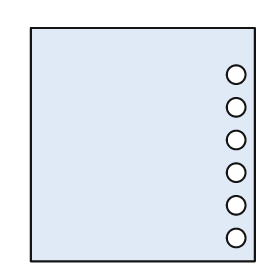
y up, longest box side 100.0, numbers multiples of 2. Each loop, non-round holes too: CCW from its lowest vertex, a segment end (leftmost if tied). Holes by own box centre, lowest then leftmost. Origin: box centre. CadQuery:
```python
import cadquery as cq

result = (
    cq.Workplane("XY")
    .moveTo(-48.0, -50.0)
    .lineTo(48.0, -50.0)
    .lineTo(48.0, 50.0)
    .lineTo(-48.0, 50.0)
    .close()
    .moveTo(40.0, -40.0)
    .circle(4.0)
    .moveTo(40.0, -26.0)
    .circle(4.0)
    .moveTo(40.0, -12.0)
    .circle(4.0)
    .moveTo(40.0, 2.0)
    .circle(4.0)
    .moveTo(40.0, 16.0)
    .circle(4.0)
    .moveTo(40.0, 30.0)
    .circle(4.0)
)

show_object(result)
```